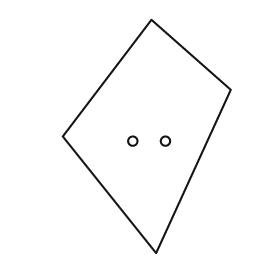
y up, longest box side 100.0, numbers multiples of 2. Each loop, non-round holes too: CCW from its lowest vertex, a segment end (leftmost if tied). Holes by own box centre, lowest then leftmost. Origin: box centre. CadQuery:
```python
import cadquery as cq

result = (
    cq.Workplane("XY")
    .moveTo(4.0, -50.0)
    .lineTo(36.0, 20.0)
    .lineTo(2.0, 50.0)
    .lineTo(-36.0, 0.0)
    .close()
    .moveTo(-6.0, -2.0)
    .circle(2.0)
    .moveTo(8.0, -2.0)
    .circle(2.0)
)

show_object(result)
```